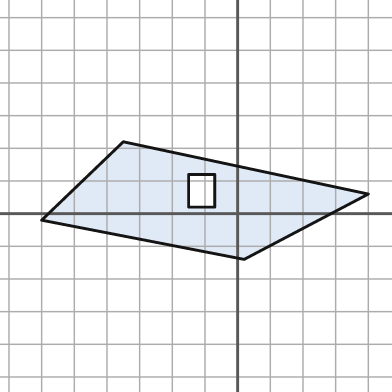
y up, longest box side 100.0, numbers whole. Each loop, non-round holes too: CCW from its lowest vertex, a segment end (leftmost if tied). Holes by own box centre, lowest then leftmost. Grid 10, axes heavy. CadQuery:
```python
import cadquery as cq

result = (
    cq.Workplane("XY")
    .moveTo(2.0, -14.0)
    .lineTo(40.0, 6.0)
    .lineTo(-35.0, 22.0)
    .lineTo(-60.0, -2.0)
    .close()
    .moveTo(-15.0, 2.0)
    .lineTo(-7.0, 2.0)
    .lineTo(-7.0, 12.0)
    .lineTo(-15.0, 12.0)
    .close()
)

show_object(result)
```